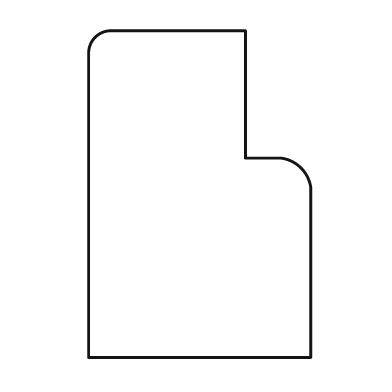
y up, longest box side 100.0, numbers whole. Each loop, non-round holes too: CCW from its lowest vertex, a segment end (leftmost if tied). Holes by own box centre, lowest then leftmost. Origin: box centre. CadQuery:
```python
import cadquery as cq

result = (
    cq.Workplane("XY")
    .moveTo(-34.0, -50.0)
    .lineTo(34.0, -50.0)
    .lineTo(34.0, 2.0)
    .threePointArc((31.0, 8.0), (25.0, 11.0))
    .lineTo(14.0, 11.0)
    .lineTo(14.0, 50.0)
    .lineTo(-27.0, 50.0)
    .threePointArc((-32.0, 48.0), (-34.0, 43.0))
    .close()
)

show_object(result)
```